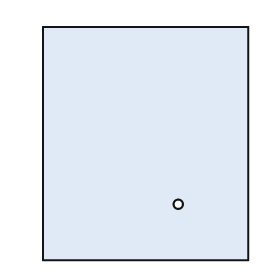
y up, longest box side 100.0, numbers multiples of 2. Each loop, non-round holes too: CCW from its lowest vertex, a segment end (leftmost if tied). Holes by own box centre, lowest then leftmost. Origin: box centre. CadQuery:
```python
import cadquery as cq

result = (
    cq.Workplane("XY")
    .moveTo(-44.0, -50.0)
    .lineTo(44.0, -50.0)
    .lineTo(44.0, 50.0)
    .lineTo(-44.0, 50.0)
    .close()
    .moveTo(14.0, -26.0)
    .circle(2.0)
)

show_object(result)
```